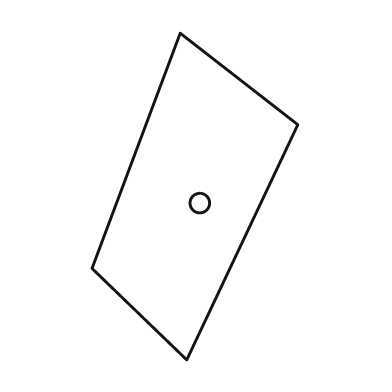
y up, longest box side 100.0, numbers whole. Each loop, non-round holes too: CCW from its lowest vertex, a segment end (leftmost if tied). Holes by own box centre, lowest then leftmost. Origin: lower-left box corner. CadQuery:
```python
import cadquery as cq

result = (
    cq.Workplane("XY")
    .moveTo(29.0, 0.0)
    .lineTo(63.0, 72.0)
    .lineTo(27.0, 100.0)
    .lineTo(0.0, 28.0)
    .close()
    .moveTo(33.0, 48.0)
    .circle(3.0)
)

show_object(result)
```